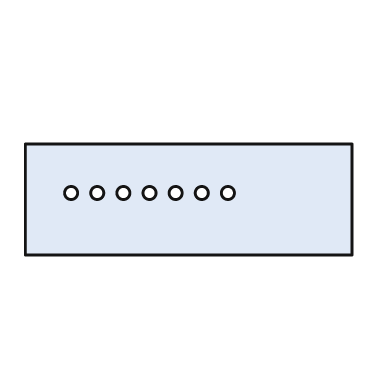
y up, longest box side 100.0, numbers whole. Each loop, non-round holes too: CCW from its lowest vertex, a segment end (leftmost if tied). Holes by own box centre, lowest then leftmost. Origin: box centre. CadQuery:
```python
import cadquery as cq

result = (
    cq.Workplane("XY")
    .moveTo(-50.0, -17.0)
    .lineTo(50.0, -17.0)
    .lineTo(50.0, 17.0)
    .lineTo(-50.0, 17.0)
    .close()
    .moveTo(-36.0, 2.0)
    .circle(2.0)
    .moveTo(-28.0, 2.0)
    .circle(2.0)
    .moveTo(-20.0, 2.0)
    .circle(2.0)
    .moveTo(-12.0, 2.0)
    .circle(2.0)
    .moveTo(-4.0, 2.0)
    .circle(2.0)
    .moveTo(4.0, 2.0)
    .circle(2.0)
    .moveTo(12.0, 2.0)
    .circle(2.0)
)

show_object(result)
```